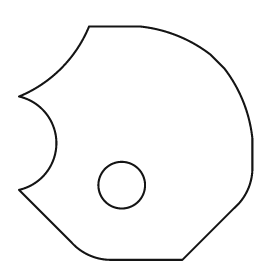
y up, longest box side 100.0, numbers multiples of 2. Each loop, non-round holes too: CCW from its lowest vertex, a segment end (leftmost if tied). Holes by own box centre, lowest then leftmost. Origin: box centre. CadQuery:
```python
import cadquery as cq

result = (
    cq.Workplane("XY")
    .moveTo(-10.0, -50.0)
    .lineTo(20.0, -50.0)
    .lineTo(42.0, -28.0)
    .threePointArc((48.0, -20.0), (50.0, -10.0))
    .lineTo(50.0, 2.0)
    .threePointArc((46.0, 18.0), (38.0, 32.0))
    .lineTo(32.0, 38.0)
    .threePointArc((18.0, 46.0), (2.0, 50.0))
    .lineTo(-20.0, 50.0)
    .threePointArc((-32.0, 32.0), (-50.0, 20.0))
    .threePointArc((-34.0, 0.0), (-50.0, -20.0))
    .lineTo(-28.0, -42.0)
    .threePointArc((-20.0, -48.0), (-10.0, -50.0))
    .close()
    .moveTo(-6.0, -18.0)
    .circle(10.0)
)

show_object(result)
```